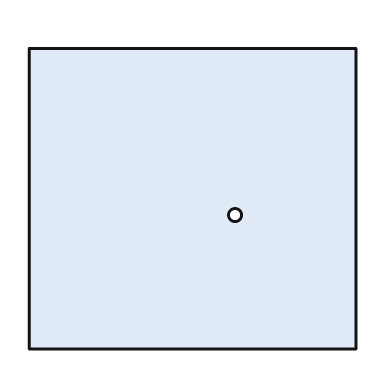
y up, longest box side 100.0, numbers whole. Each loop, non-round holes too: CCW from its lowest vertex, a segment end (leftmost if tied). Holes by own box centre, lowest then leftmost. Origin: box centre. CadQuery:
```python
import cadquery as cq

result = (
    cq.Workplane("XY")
    .moveTo(-50.0, -46.0)
    .lineTo(50.0, -46.0)
    .lineTo(50.0, 46.0)
    .lineTo(-50.0, 46.0)
    .close()
    .moveTo(13.0, -5.0)
    .circle(2.0)
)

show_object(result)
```